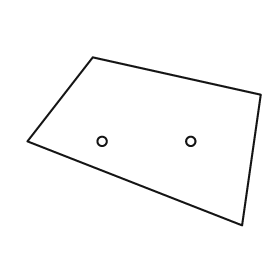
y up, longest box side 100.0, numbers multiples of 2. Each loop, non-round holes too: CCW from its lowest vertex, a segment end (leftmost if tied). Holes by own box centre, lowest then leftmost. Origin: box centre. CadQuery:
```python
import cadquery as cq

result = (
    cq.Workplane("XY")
    .moveTo(42.0, -36.0)
    .lineTo(50.0, 20.0)
    .lineTo(-22.0, 36.0)
    .lineTo(-50.0, 0.0)
    .close()
    .moveTo(-18.0, 0.0)
    .circle(2.0)
    .moveTo(20.0, 0.0)
    .circle(2.0)
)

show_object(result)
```